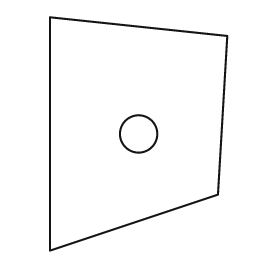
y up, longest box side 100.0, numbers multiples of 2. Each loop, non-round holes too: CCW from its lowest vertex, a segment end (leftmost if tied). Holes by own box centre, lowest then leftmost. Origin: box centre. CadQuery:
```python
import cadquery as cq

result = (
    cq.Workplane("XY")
    .moveTo(-38.0, -50.0)
    .lineTo(34.0, -26.0)
    .lineTo(38.0, 42.0)
    .lineTo(-38.0, 50.0)
    .close()
    .moveTo(0.0, 0.0)
    .circle(8.0)
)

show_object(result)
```